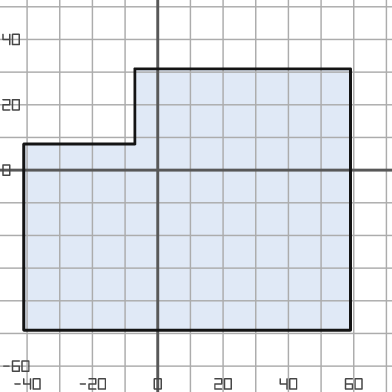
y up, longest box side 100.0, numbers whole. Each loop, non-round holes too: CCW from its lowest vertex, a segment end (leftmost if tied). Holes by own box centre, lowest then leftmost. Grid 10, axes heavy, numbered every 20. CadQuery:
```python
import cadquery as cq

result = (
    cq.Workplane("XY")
    .moveTo(-41.0, -49.0)
    .lineTo(59.0, -49.0)
    .lineTo(59.0, 31.0)
    .lineTo(-7.0, 31.0)
    .lineTo(-7.0, 8.0)
    .lineTo(-41.0, 8.0)
    .close()
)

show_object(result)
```